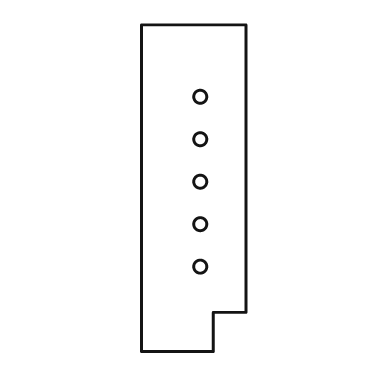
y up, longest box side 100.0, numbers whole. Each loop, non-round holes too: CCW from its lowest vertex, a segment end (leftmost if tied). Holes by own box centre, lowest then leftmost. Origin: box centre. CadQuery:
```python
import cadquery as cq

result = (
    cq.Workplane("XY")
    .moveTo(-16.0, -50.0)
    .lineTo(6.0, -50.0)
    .lineTo(6.0, -38.0)
    .lineTo(16.0, -38.0)
    .lineTo(16.0, 50.0)
    .lineTo(-16.0, 50.0)
    .close()
    .moveTo(2.0, -24.0)
    .circle(2.0)
    .moveTo(2.0, -11.0)
    .circle(2.0)
    .moveTo(2.0, 2.0)
    .circle(2.0)
    .moveTo(2.0, 15.0)
    .circle(2.0)
    .moveTo(2.0, 28.0)
    .circle(2.0)
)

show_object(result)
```